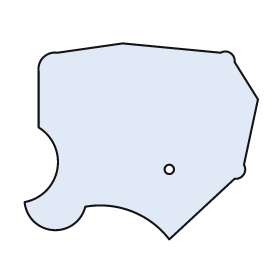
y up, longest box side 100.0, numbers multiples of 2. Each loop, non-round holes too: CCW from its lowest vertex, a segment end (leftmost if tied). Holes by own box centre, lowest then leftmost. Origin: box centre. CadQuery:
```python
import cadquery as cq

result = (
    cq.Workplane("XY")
    .moveTo(12.0, -42.0)
    .lineTo(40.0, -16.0)
    .threePointArc((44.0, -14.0), (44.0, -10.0))
    .lineTo(50.0, 18.0)
    .lineTo(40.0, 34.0)
    .threePointArc((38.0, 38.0), (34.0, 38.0))
    .lineTo(-8.0, 42.0)
    .lineTo(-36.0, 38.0)
    .threePointArc((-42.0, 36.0), (-44.0, 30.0))
    .lineTo(-44.0, 6.0)
    .threePointArc((-36.0, -12.0), (-50.0, -26.0))
    .threePointArc((-38.0, -38.0), (-24.0, -28.0))
    .threePointArc((-4.0, -30.0), (12.0, -42.0))
    .close()
    .moveTo(12.0, -12.0)
    .circle(2.0)
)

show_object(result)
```